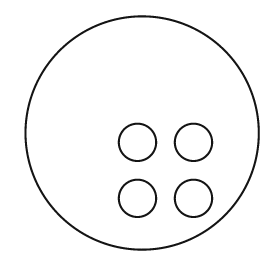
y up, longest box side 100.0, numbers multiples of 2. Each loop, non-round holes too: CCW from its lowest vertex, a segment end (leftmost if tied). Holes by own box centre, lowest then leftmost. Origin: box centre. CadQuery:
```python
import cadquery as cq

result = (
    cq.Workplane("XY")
    .moveTo(0.0, 0.0)
    .circle(50.0)
    .moveTo(-2.0, -28.0)
    .circle(8.0)
    .moveTo(22.0, -28.0)
    .circle(8.0)
    .moveTo(-2.0, -4.0)
    .circle(8.0)
    .moveTo(22.0, -4.0)
    .circle(8.0)
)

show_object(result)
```